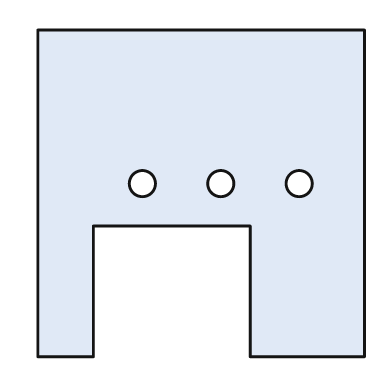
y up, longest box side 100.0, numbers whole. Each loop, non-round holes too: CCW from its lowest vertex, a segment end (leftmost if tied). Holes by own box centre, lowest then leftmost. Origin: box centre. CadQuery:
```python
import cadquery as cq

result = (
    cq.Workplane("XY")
    .moveTo(-50.0, -50.0)
    .lineTo(-33.0, -50.0)
    .lineTo(-33.0, -10.0)
    .lineTo(15.0, -10.0)
    .lineTo(15.0, -50.0)
    .lineTo(50.0, -50.0)
    .lineTo(50.0, 50.0)
    .lineTo(-50.0, 50.0)
    .close()
    .moveTo(-18.0, 3.0)
    .circle(4.0)
    .moveTo(6.0, 3.0)
    .circle(4.0)
    .moveTo(30.0, 3.0)
    .circle(4.0)
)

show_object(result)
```